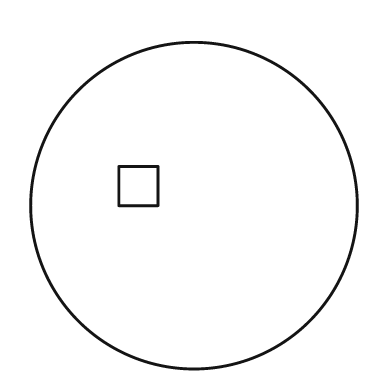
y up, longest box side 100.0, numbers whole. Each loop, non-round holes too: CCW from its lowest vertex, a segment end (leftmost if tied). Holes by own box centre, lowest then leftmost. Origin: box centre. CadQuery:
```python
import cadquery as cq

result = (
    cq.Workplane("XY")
    .moveTo(0.0, 0.0)
    .circle(50.0)
    .moveTo(-23.0, 0.0)
    .lineTo(-11.0, 0.0)
    .lineTo(-11.0, 12.0)
    .lineTo(-23.0, 12.0)
    .close()
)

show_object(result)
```